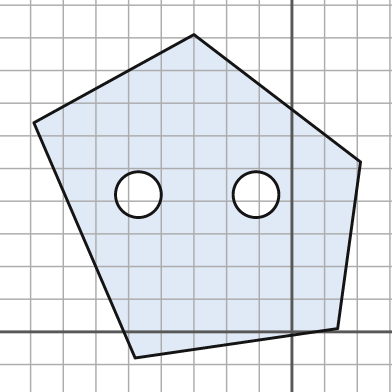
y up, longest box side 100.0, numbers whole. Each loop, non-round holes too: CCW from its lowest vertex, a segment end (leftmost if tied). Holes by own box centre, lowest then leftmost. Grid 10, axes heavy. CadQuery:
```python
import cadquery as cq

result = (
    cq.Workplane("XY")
    .moveTo(-48.0, -8.0)
    .lineTo(14.0, 1.0)
    .lineTo(21.0, 52.0)
    .lineTo(-30.0, 91.0)
    .lineTo(-79.0, 64.0)
    .close()
    .moveTo(-47.0, 42.0)
    .circle(7.0)
    .moveTo(-11.0, 42.0)
    .circle(7.0)
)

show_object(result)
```